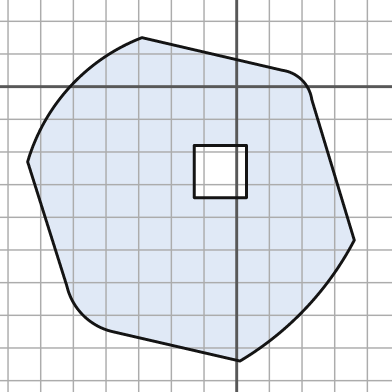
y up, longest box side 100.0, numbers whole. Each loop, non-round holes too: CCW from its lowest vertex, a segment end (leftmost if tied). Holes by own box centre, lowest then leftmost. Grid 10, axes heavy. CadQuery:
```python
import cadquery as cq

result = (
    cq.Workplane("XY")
    .moveTo(1.0, -84.0)
    .threePointArc((21.0, -68.0), (36.0, -47.0))
    .lineTo(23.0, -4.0)
    .threePointArc((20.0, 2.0), (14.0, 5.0))
    .lineTo(-29.0, 15.0)
    .threePointArc((-51.0, 0.0), (-64.0, -23.0))
    .lineTo(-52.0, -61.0)
    .threePointArc((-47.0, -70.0), (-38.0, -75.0))
    .close()
    .moveTo(-13.0, -34.0)
    .lineTo(3.0, -34.0)
    .lineTo(3.0, -18.0)
    .lineTo(-13.0, -18.0)
    .close()
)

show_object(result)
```